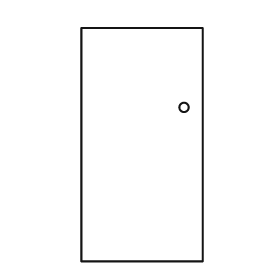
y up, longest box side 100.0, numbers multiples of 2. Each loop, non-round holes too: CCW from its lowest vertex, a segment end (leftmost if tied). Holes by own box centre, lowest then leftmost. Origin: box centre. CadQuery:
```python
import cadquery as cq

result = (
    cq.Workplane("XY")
    .moveTo(-26.0, -50.0)
    .lineTo(26.0, -50.0)
    .lineTo(26.0, 50.0)
    .lineTo(-26.0, 50.0)
    .close()
    .moveTo(18.0, 16.0)
    .circle(2.0)
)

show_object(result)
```